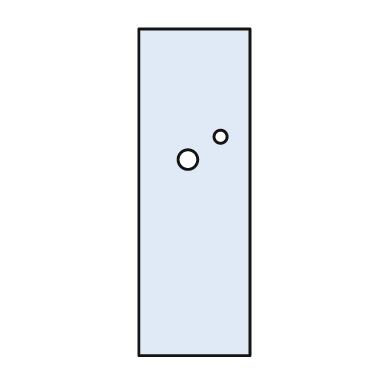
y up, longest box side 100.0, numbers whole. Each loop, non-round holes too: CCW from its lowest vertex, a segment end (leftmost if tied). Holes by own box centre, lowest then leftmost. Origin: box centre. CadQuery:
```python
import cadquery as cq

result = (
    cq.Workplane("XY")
    .moveTo(-17.0, -50.0)
    .lineTo(17.0, -50.0)
    .lineTo(17.0, 50.0)
    .lineTo(-17.0, 50.0)
    .close()
    .moveTo(-2.0, 10.0)
    .circle(3.0)
    .moveTo(8.0, 17.0)
    .circle(2.0)
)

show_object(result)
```